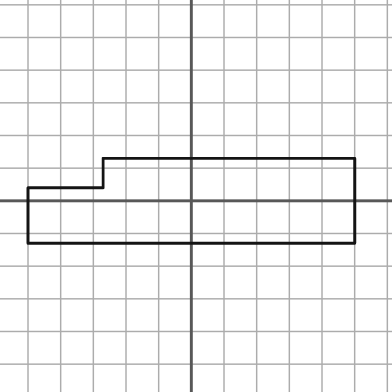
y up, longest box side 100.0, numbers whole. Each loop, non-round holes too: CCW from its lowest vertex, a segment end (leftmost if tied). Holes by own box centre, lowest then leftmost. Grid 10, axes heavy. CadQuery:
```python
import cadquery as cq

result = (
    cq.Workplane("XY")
    .moveTo(-50.0, -13.0)
    .lineTo(50.0, -13.0)
    .lineTo(50.0, 13.0)
    .lineTo(-27.0, 13.0)
    .lineTo(-27.0, 4.0)
    .lineTo(-50.0, 4.0)
    .close()
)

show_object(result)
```